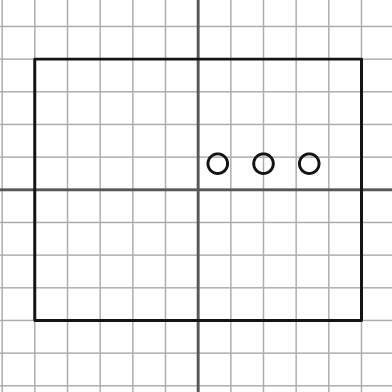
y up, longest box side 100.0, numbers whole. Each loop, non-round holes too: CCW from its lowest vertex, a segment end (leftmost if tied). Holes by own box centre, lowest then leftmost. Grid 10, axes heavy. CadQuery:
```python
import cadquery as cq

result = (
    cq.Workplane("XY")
    .moveTo(-50.0, -40.0)
    .lineTo(50.0, -40.0)
    .lineTo(50.0, 40.0)
    .lineTo(-50.0, 40.0)
    .close()
    .moveTo(6.0, 8.0)
    .circle(3.0)
    .moveTo(20.0, 8.0)
    .circle(3.0)
    .moveTo(34.0, 8.0)
    .circle(3.0)
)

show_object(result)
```